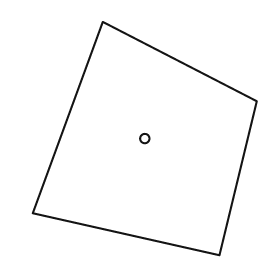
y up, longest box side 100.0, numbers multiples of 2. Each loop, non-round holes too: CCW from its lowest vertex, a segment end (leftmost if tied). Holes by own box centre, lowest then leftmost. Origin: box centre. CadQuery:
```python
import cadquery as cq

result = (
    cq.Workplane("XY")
    .moveTo(32.0, -50.0)
    .lineTo(48.0, 16.0)
    .lineTo(-18.0, 50.0)
    .lineTo(-48.0, -32.0)
    .close()
    .moveTo(0.0, 0.0)
    .circle(2.0)
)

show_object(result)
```